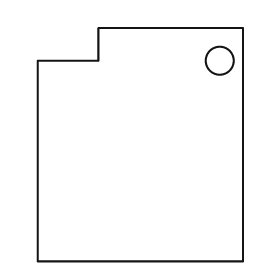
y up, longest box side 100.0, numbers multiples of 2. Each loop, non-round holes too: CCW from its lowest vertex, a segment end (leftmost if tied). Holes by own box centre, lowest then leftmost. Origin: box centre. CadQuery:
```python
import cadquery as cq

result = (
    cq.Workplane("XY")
    .moveTo(-44.0, -50.0)
    .lineTo(44.0, -50.0)
    .lineTo(44.0, 50.0)
    .lineTo(-18.0, 50.0)
    .lineTo(-18.0, 36.0)
    .lineTo(-44.0, 36.0)
    .close()
    .moveTo(34.0, 36.0)
    .circle(6.0)
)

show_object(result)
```